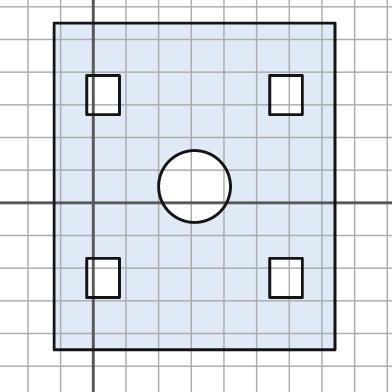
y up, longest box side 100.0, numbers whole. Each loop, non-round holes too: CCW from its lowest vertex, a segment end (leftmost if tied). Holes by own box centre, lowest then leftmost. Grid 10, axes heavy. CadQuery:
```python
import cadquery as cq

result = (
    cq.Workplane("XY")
    .moveTo(-12.0, -45.0)
    .lineTo(74.0, -45.0)
    .lineTo(74.0, 55.0)
    .lineTo(-12.0, 55.0)
    .close()
    .moveTo(-2.0, -29.0)
    .lineTo(8.0, -29.0)
    .lineTo(8.0, -17.0)
    .lineTo(-2.0, -17.0)
    .close()
    .moveTo(54.0, -29.0)
    .lineTo(64.0, -29.0)
    .lineTo(64.0, -17.0)
    .lineTo(54.0, -17.0)
    .close()
    .moveTo(31.0, 5.0)
    .circle(11.0)
    .moveTo(-2.0, 27.0)
    .lineTo(8.0, 27.0)
    .lineTo(8.0, 39.0)
    .lineTo(-2.0, 39.0)
    .close()
    .moveTo(54.0, 27.0)
    .lineTo(64.0, 27.0)
    .lineTo(64.0, 39.0)
    .lineTo(54.0, 39.0)
    .close()
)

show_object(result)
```